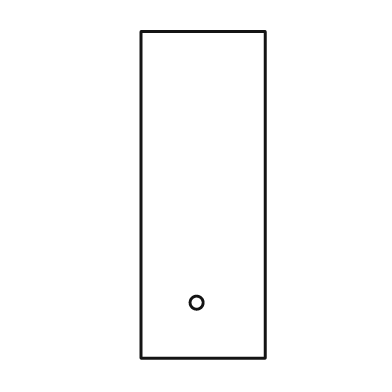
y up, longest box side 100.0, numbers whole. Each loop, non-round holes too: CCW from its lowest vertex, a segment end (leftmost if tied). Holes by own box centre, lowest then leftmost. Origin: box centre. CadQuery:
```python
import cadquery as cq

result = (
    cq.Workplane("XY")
    .moveTo(-19.0, -50.0)
    .lineTo(19.0, -50.0)
    .lineTo(19.0, 50.0)
    .lineTo(-19.0, 50.0)
    .close()
    .moveTo(-2.0, -33.0)
    .circle(2.0)
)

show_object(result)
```